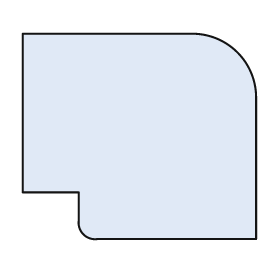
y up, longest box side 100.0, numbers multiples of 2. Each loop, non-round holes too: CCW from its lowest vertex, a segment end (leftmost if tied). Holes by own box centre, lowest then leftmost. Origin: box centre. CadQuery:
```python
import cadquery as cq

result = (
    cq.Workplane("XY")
    .moveTo(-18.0, -44.0)
    .lineTo(50.0, -44.0)
    .lineTo(50.0, 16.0)
    .threePointArc((42.0, 36.0), (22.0, 44.0))
    .lineTo(-50.0, 44.0)
    .lineTo(-50.0, -24.0)
    .lineTo(-26.0, -24.0)
    .lineTo(-26.0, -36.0)
    .threePointArc((-24.0, -42.0), (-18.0, -44.0))
    .close()
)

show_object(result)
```